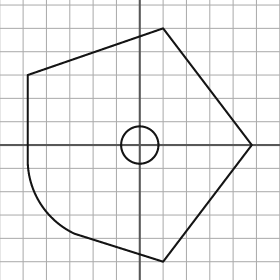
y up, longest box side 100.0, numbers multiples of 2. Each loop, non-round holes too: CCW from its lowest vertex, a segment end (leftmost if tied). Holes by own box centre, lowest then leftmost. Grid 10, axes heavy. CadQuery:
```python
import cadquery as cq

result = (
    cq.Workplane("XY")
    .moveTo(10.0, -50.0)
    .lineTo(48.0, 0.0)
    .lineTo(10.0, 50.0)
    .lineTo(-48.0, 30.0)
    .lineTo(-48.0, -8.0)
    .threePointArc((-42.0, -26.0), (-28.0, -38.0))
    .close()
    .moveTo(0.0, 0.0)
    .circle(8.0)
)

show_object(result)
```